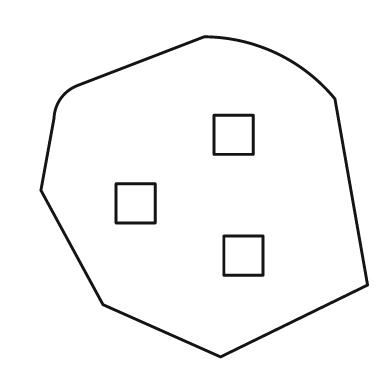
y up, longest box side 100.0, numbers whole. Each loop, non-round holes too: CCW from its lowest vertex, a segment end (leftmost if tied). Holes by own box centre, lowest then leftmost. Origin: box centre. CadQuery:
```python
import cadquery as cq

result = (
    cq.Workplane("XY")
    .moveTo(5.0, -49.0)
    .lineTo(50.0, -27.0)
    .lineTo(40.0, 30.0)
    .threePointArc((22.0, 44.0), (0.0, 49.0))
    .lineTo(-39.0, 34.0)
    .threePointArc((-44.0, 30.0), (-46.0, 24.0))
    .lineTo(-50.0, 2.0)
    .lineTo(-31.0, -33.0)
    .close()
    .moveTo(6.0, -24.0)
    .lineTo(18.0, -24.0)
    .lineTo(18.0, -12.0)
    .lineTo(6.0, -12.0)
    .close()
    .moveTo(-27.0, -8.0)
    .lineTo(-15.0, -8.0)
    .lineTo(-15.0, 4.0)
    .lineTo(-27.0, 4.0)
    .close()
    .moveTo(3.0, 13.0)
    .lineTo(15.0, 13.0)
    .lineTo(15.0, 25.0)
    .lineTo(3.0, 25.0)
    .close()
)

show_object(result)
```